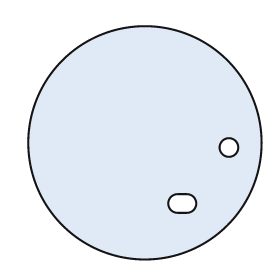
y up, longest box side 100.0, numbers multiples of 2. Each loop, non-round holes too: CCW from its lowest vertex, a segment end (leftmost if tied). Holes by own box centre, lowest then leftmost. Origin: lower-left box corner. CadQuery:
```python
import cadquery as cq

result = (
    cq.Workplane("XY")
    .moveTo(50.0, 50.0)
    .circle(50.0)
    .moveTo(64.0, 20.0)
    .lineTo(68.0, 20.0)
    .threePointArc((72.0, 24.0), (68.0, 28.0))
    .lineTo(64.0, 28.0)
    .threePointArc((60.0, 24.0), (64.0, 20.0))
    .close()
    .moveTo(86.0, 48.0)
    .circle(4.0)
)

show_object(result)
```